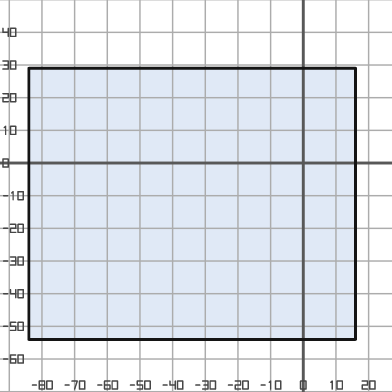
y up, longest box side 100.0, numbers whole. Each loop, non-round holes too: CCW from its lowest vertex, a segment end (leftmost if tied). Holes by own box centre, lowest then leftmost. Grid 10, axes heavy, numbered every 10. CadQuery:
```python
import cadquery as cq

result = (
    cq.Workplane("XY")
    .moveTo(-84.0, -54.0)
    .lineTo(16.0, -54.0)
    .lineTo(16.0, 29.0)
    .lineTo(-84.0, 29.0)
    .close()
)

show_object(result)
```